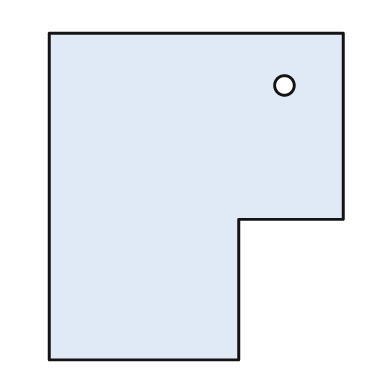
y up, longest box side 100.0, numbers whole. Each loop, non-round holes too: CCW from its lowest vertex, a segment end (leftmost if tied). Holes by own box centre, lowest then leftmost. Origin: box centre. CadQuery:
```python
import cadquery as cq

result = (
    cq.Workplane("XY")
    .moveTo(-45.0, -50.0)
    .lineTo(13.0, -50.0)
    .lineTo(13.0, -7.0)
    .lineTo(45.0, -7.0)
    .lineTo(45.0, 50.0)
    .lineTo(-45.0, 50.0)
    .close()
    .moveTo(27.0, 34.0)
    .circle(3.0)
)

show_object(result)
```